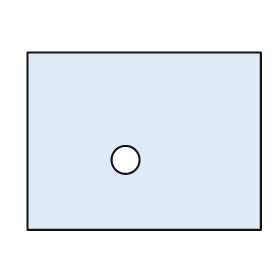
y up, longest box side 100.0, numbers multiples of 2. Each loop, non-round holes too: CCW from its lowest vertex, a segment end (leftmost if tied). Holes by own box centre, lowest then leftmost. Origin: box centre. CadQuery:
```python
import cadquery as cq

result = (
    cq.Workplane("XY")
    .moveTo(-50.0, -38.0)
    .lineTo(50.0, -38.0)
    .lineTo(50.0, 38.0)
    .lineTo(-50.0, 38.0)
    .close()
    .moveTo(-8.0, -8.0)
    .circle(6.0)
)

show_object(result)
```